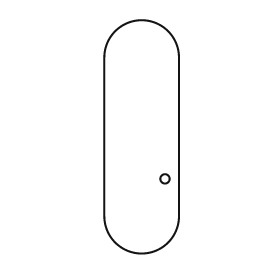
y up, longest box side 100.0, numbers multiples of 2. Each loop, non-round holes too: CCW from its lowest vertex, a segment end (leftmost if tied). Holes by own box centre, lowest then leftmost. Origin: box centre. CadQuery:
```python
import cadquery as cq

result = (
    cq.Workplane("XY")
    .moveTo(-16.0, -34.0)
    .threePointArc((0.0, -50.0), (16.0, -34.0))
    .lineTo(16.0, 34.0)
    .threePointArc((0.0, 50.0), (-16.0, 34.0))
    .close()
    .moveTo(10.0, -18.0)
    .circle(2.0)
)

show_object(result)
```